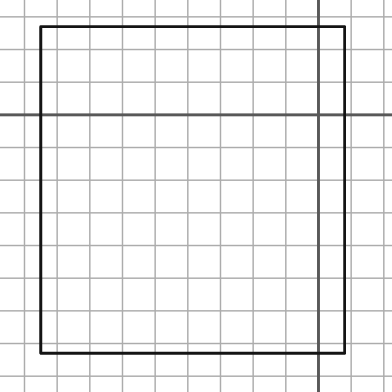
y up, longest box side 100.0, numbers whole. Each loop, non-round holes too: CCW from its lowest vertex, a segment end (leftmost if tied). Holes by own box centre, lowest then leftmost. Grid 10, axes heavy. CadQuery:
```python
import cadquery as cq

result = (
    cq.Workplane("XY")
    .moveTo(-85.0, -73.0)
    .lineTo(8.0, -73.0)
    .lineTo(8.0, 27.0)
    .lineTo(-85.0, 27.0)
    .close()
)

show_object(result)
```